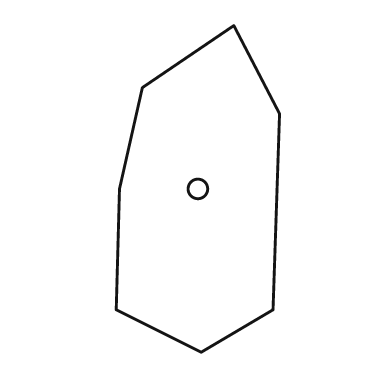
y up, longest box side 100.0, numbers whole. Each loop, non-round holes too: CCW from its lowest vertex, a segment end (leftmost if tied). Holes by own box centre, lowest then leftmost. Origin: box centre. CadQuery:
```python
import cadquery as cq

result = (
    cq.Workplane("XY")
    .moveTo(1.0, -50.0)
    .lineTo(23.0, -37.0)
    .lineTo(25.0, 23.0)
    .lineTo(11.0, 50.0)
    .lineTo(-17.0, 31.0)
    .lineTo(-24.0, 0.0)
    .lineTo(-25.0, -37.0)
    .close()
    .moveTo(0.0, 0.0)
    .circle(3.0)
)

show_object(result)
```